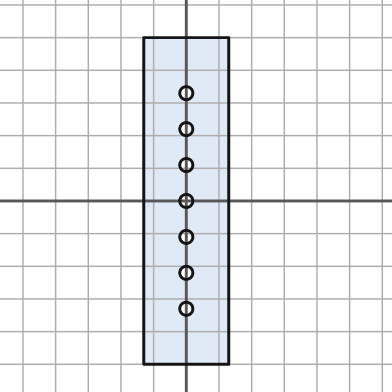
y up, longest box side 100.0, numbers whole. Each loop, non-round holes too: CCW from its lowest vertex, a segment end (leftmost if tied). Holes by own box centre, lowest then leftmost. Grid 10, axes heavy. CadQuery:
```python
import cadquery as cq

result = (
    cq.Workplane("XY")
    .moveTo(-13.0, -50.0)
    .lineTo(13.0, -50.0)
    .lineTo(13.0, 50.0)
    .lineTo(-13.0, 50.0)
    .close()
    .moveTo(0.0, -33.0)
    .circle(2.0)
    .moveTo(0.0, -22.0)
    .circle(2.0)
    .moveTo(0.0, -11.0)
    .circle(2.0)
    .moveTo(0.0, 0.0)
    .circle(2.0)
    .moveTo(0.0, 11.0)
    .circle(2.0)
    .moveTo(0.0, 22.0)
    .circle(2.0)
    .moveTo(0.0, 33.0)
    .circle(2.0)
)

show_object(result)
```